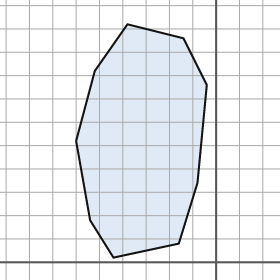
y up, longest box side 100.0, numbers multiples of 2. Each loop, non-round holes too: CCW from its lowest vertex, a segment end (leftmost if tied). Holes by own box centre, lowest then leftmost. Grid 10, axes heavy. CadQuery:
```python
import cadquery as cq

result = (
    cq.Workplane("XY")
    .moveTo(-44.0, 2.0)
    .lineTo(-16.0, 8.0)
    .lineTo(-8.0, 34.0)
    .lineTo(-4.0, 76.0)
    .lineTo(-14.0, 96.0)
    .lineTo(-38.0, 102.0)
    .lineTo(-52.0, 82.0)
    .lineTo(-60.0, 52.0)
    .lineTo(-54.0, 18.0)
    .close()
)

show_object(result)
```